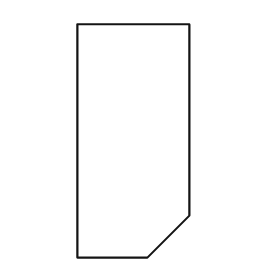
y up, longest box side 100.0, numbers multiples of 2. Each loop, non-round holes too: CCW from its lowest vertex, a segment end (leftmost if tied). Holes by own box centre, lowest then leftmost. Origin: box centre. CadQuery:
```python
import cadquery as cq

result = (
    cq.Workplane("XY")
    .moveTo(-24.0, -50.0)
    .lineTo(6.0, -50.0)
    .lineTo(24.0, -32.0)
    .lineTo(24.0, 50.0)
    .lineTo(-24.0, 50.0)
    .close()
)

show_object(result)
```